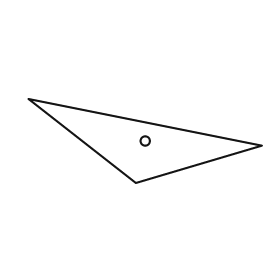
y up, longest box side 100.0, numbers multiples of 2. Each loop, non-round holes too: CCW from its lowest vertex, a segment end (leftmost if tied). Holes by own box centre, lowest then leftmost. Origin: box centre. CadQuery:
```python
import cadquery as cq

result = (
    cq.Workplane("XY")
    .moveTo(-4.0, -18.0)
    .lineTo(50.0, -2.0)
    .lineTo(-50.0, 18.0)
    .close()
    .moveTo(0.0, 0.0)
    .circle(2.0)
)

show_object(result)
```